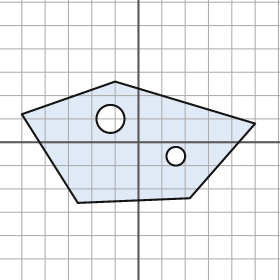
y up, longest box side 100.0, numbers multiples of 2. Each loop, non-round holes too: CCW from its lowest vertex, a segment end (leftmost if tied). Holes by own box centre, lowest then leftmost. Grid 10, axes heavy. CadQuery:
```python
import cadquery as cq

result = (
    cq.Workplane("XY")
    .moveTo(-26.0, -26.0)
    .lineTo(22.0, -24.0)
    .lineTo(50.0, 8.0)
    .lineTo(-10.0, 26.0)
    .lineTo(-50.0, 12.0)
    .close()
    .moveTo(16.0, -6.0)
    .circle(4.0)
    .moveTo(-12.0, 10.0)
    .circle(6.0)
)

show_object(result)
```